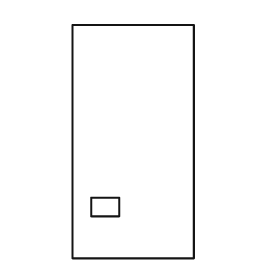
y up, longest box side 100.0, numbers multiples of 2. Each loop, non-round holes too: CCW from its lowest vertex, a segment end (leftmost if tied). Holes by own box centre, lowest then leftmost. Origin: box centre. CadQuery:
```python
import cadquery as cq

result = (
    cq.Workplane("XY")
    .moveTo(-26.0, -50.0)
    .lineTo(26.0, -50.0)
    .lineTo(26.0, 50.0)
    .lineTo(-26.0, 50.0)
    .close()
    .moveTo(-18.0, -32.0)
    .lineTo(-6.0, -32.0)
    .lineTo(-6.0, -24.0)
    .lineTo(-18.0, -24.0)
    .close()
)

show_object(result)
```